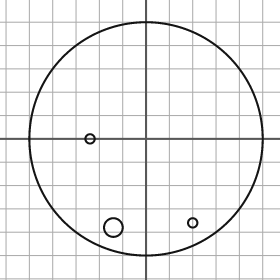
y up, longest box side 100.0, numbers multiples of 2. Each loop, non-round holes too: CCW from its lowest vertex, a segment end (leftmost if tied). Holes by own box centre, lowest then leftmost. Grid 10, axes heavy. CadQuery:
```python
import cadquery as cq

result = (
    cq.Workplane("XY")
    .moveTo(0.0, 0.0)
    .circle(50.0)
    .moveTo(-14.0, -38.0)
    .circle(4.0)
    .moveTo(20.0, -36.0)
    .circle(2.0)
    .moveTo(-24.0, 0.0)
    .circle(2.0)
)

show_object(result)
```